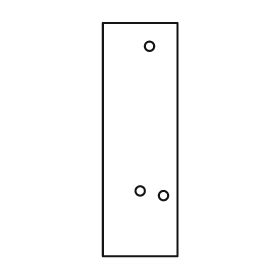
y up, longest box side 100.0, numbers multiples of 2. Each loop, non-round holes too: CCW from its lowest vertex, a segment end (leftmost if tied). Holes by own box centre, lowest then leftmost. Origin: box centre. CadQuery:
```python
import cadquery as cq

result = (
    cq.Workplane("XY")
    .moveTo(-16.0, -50.0)
    .lineTo(16.0, -50.0)
    .lineTo(16.0, 50.0)
    .lineTo(-16.0, 50.0)
    .close()
    .moveTo(10.0, -24.0)
    .circle(2.0)
    .moveTo(0.0, -22.0)
    .circle(2.0)
    .moveTo(4.0, 40.0)
    .circle(2.0)
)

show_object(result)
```